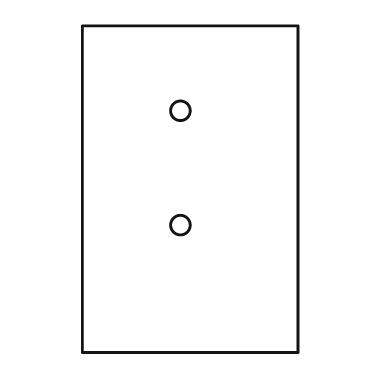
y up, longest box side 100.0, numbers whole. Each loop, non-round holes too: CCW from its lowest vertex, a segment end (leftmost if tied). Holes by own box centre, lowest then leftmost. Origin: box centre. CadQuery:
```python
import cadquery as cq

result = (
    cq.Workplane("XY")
    .moveTo(-33.0, -50.0)
    .lineTo(33.0, -50.0)
    .lineTo(33.0, 50.0)
    .lineTo(-33.0, 50.0)
    .close()
    .moveTo(-3.0, -11.0)
    .circle(3.0)
    .moveTo(-3.0, 24.0)
    .circle(3.0)
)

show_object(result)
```